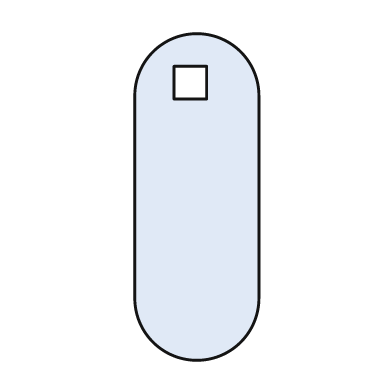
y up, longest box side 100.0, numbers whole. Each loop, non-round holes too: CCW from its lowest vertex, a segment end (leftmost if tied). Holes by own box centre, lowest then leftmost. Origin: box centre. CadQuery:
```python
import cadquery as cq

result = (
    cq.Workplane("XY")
    .moveTo(-19.0, -31.0)
    .threePointArc((0.0, -50.0), (19.0, -31.0))
    .lineTo(19.0, 31.0)
    .threePointArc((0.0, 50.0), (-19.0, 31.0))
    .close()
    .moveTo(-7.0, 30.0)
    .lineTo(3.0, 30.0)
    .lineTo(3.0, 40.0)
    .lineTo(-7.0, 40.0)
    .close()
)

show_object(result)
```